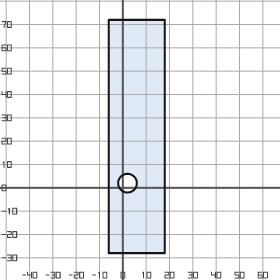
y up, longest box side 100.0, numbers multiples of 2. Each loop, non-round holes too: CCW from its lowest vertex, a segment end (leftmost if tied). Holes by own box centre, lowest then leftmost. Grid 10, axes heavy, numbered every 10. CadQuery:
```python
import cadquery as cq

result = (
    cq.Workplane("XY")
    .moveTo(-6.0, -28.0)
    .lineTo(18.0, -28.0)
    .lineTo(18.0, 72.0)
    .lineTo(-6.0, 72.0)
    .close()
    .moveTo(2.0, 2.0)
    .circle(4.0)
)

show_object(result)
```